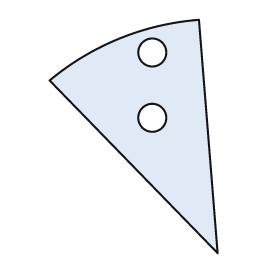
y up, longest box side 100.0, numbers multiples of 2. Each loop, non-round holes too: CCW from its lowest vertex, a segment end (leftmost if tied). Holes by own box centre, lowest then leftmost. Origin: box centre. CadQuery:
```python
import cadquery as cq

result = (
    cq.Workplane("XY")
    .moveTo(36.0, -50.0)
    .lineTo(28.0, 50.0)
    .threePointArc((-6.0, 42.0), (-36.0, 24.0))
    .close()
    .moveTo(8.0, 8.0)
    .circle(6.0)
    .moveTo(8.0, 36.0)
    .circle(6.0)
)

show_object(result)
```